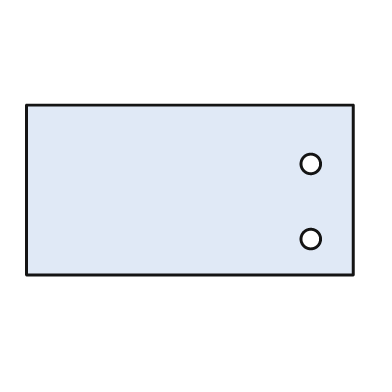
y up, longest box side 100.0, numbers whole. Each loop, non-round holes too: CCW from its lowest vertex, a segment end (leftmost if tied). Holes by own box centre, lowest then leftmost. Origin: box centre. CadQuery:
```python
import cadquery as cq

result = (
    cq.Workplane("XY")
    .moveTo(-50.0, -26.0)
    .lineTo(50.0, -26.0)
    .lineTo(50.0, 26.0)
    .lineTo(-50.0, 26.0)
    .close()
    .moveTo(37.0, -15.0)
    .circle(3.0)
    .moveTo(37.0, 8.0)
    .circle(3.0)
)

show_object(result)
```